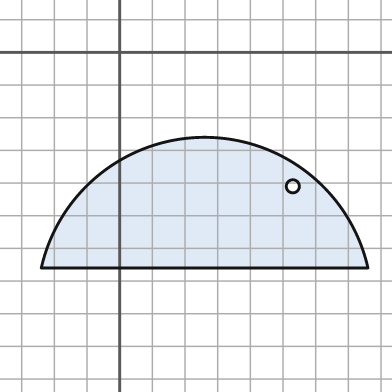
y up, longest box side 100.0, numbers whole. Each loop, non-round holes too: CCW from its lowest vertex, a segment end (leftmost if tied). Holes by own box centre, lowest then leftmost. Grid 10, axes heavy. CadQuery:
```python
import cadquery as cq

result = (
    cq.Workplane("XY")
    .moveTo(-24.0, -66.0)
    .lineTo(76.0, -66.0)
    .threePointArc((26.0, -26.0), (-24.0, -66.0))
    .close()
    .moveTo(53.0, -41.0)
    .circle(2.0)
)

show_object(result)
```